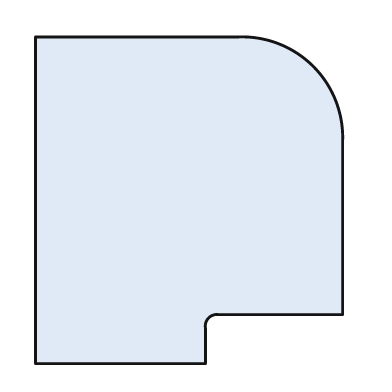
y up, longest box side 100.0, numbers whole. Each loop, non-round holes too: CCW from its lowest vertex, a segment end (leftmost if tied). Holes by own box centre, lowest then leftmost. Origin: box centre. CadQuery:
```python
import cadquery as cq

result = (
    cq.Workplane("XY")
    .moveTo(-47.0, -50.0)
    .lineTo(5.0, -50.0)
    .lineTo(5.0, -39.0)
    .threePointArc((6.0, -36.0), (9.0, -35.0))
    .lineTo(47.0, -35.0)
    .lineTo(47.0, 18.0)
    .threePointArc((38.0, 41.0), (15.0, 50.0))
    .lineTo(-47.0, 50.0)
    .close()
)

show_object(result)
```